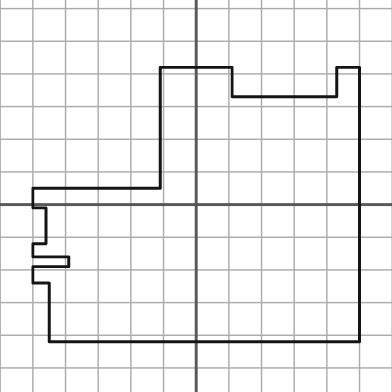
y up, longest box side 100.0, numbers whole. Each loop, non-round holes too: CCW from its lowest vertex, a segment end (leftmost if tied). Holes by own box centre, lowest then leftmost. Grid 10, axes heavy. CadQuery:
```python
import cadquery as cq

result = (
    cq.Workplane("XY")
    .moveTo(-45.0, -42.0)
    .lineTo(50.0, -42.0)
    .lineTo(50.0, 42.0)
    .lineTo(43.0, 42.0)
    .lineTo(43.0, 33.0)
    .lineTo(11.0, 33.0)
    .lineTo(11.0, 42.0)
    .lineTo(-11.0, 42.0)
    .lineTo(-11.0, 5.0)
    .lineTo(-50.0, 5.0)
    .lineTo(-50.0, -1.0)
    .lineTo(-46.0, -1.0)
    .lineTo(-46.0, -12.0)
    .lineTo(-50.0, -12.0)
    .lineTo(-50.0, -16.0)
    .lineTo(-39.0, -16.0)
    .lineTo(-39.0, -19.0)
    .lineTo(-50.0, -19.0)
    .lineTo(-50.0, -24.0)
    .lineTo(-45.0, -24.0)
    .close()
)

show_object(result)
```